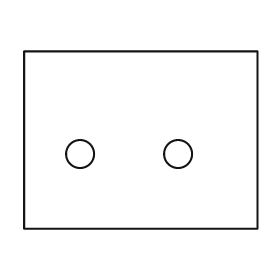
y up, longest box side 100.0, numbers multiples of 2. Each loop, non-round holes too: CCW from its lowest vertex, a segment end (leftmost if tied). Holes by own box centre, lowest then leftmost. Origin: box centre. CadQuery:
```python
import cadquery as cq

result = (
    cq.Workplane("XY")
    .moveTo(-50.0, -38.0)
    .lineTo(50.0, -38.0)
    .lineTo(50.0, 38.0)
    .lineTo(-50.0, 38.0)
    .close()
    .moveTo(-26.0, -6.0)
    .circle(6.0)
    .moveTo(16.0, -6.0)
    .circle(6.0)
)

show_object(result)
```